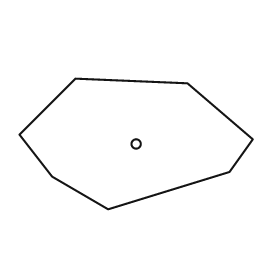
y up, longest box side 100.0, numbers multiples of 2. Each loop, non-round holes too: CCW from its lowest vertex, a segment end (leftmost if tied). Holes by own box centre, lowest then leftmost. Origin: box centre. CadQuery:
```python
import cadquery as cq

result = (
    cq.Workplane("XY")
    .moveTo(-12.0, -28.0)
    .lineTo(40.0, -12.0)
    .lineTo(50.0, 2.0)
    .lineTo(22.0, 26.0)
    .lineTo(-26.0, 28.0)
    .lineTo(-50.0, 4.0)
    .lineTo(-36.0, -14.0)
    .close()
    .moveTo(0.0, 0.0)
    .circle(2.0)
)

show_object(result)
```